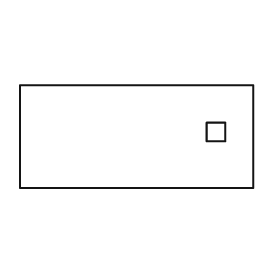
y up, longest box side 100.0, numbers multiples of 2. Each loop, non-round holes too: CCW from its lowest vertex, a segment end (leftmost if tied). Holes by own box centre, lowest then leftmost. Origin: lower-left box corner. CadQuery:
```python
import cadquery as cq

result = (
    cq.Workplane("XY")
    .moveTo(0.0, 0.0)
    .lineTo(100.0, 0.0)
    .lineTo(100.0, 44.0)
    .lineTo(0.0, 44.0)
    .close()
    .moveTo(80.0, 20.0)
    .lineTo(88.0, 20.0)
    .lineTo(88.0, 28.0)
    .lineTo(80.0, 28.0)
    .close()
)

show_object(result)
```